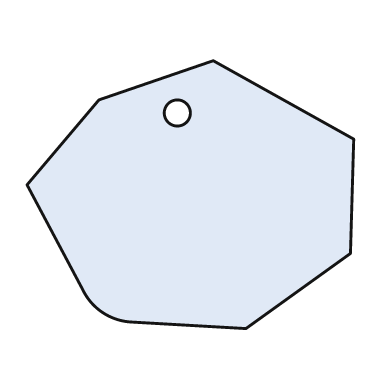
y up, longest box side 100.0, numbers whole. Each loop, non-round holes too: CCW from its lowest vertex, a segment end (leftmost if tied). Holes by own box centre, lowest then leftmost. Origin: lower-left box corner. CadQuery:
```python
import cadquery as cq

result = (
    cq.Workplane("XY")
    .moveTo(67.0, 0.0)
    .lineTo(99.0, 23.0)
    .lineTo(100.0, 58.0)
    .lineTo(57.0, 82.0)
    .lineTo(22.0, 70.0)
    .lineTo(0.0, 44.0)
    .lineTo(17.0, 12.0)
    .threePointArc((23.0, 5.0), (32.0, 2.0))
    .close()
    .moveTo(46.0, 66.0)
    .circle(4.0)
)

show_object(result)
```